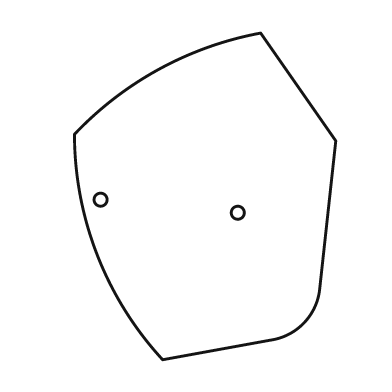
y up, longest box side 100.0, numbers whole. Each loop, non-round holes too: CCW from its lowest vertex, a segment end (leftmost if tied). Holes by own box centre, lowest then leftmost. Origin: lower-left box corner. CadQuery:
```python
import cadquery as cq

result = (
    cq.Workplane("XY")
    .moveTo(27.0, 0.0)
    .lineTo(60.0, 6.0)
    .threePointArc((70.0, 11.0), (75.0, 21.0))
    .lineTo(80.0, 67.0)
    .lineTo(57.0, 100.0)
    .threePointArc((26.0, 89.0), (0.0, 69.0))
    .threePointArc((7.0, 32.0), (27.0, 0.0))
    .close()
    .moveTo(50.0, 45.0)
    .circle(2.0)
    .moveTo(8.0, 49.0)
    .circle(2.0)
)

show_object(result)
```